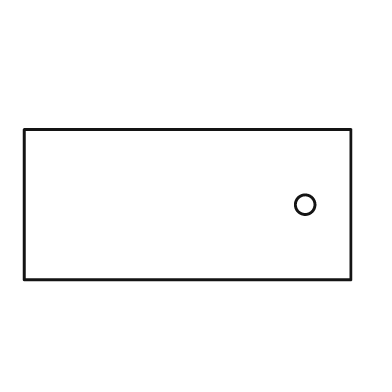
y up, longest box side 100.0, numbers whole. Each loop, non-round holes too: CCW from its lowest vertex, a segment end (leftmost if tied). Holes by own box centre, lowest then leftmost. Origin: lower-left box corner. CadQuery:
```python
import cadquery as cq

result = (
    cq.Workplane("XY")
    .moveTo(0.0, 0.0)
    .lineTo(100.0, 0.0)
    .lineTo(100.0, 46.0)
    .lineTo(0.0, 46.0)
    .close()
    .moveTo(86.0, 23.0)
    .circle(3.0)
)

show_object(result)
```